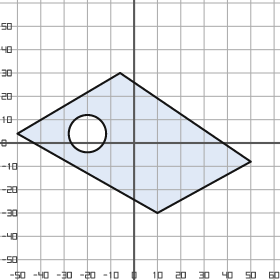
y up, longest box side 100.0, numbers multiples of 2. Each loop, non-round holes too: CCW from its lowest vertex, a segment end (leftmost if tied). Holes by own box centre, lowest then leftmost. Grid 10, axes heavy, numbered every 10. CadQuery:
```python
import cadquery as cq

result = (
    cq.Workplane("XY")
    .moveTo(10.0, -30.0)
    .lineTo(50.0, -8.0)
    .lineTo(-6.0, 30.0)
    .lineTo(-50.0, 4.0)
    .close()
    .moveTo(-20.0, 4.0)
    .circle(8.0)
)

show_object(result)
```